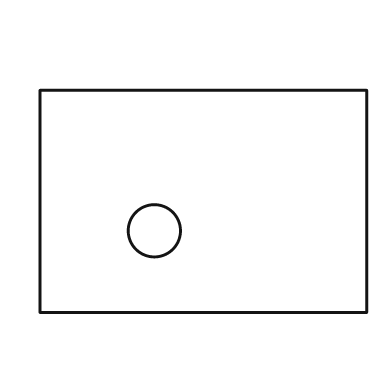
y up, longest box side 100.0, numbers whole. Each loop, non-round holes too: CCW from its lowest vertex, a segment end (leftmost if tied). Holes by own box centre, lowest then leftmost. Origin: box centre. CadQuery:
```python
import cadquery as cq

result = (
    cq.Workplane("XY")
    .moveTo(-50.0, -34.0)
    .lineTo(50.0, -34.0)
    .lineTo(50.0, 34.0)
    .lineTo(-50.0, 34.0)
    .close()
    .moveTo(-15.0, -9.0)
    .circle(8.0)
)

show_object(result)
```